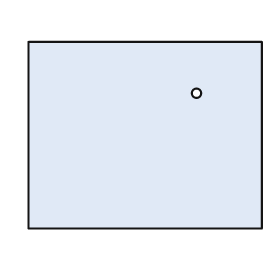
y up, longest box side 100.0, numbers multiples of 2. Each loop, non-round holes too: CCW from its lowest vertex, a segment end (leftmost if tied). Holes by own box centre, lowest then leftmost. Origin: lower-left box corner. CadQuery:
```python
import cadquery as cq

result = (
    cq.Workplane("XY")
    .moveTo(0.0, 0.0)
    .lineTo(100.0, 0.0)
    .lineTo(100.0, 80.0)
    .lineTo(0.0, 80.0)
    .close()
    .moveTo(72.0, 58.0)
    .circle(2.0)
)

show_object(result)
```